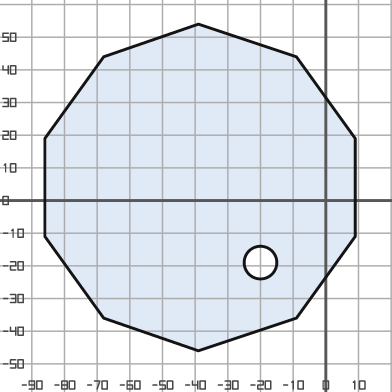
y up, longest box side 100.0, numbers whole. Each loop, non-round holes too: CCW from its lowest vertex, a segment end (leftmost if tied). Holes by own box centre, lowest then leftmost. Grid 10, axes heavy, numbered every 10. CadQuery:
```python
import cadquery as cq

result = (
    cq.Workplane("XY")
    .moveTo(-39.0, -46.0)
    .lineTo(-9.0, -36.0)
    .lineTo(9.0, -11.0)
    .lineTo(9.0, 19.0)
    .lineTo(-9.0, 44.0)
    .lineTo(-39.0, 54.0)
    .lineTo(-68.0, 44.0)
    .lineTo(-86.0, 19.0)
    .lineTo(-86.0, -11.0)
    .lineTo(-68.0, -36.0)
    .close()
    .moveTo(-20.0, -19.0)
    .circle(5.0)
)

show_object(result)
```